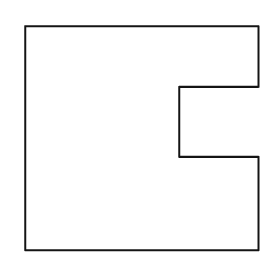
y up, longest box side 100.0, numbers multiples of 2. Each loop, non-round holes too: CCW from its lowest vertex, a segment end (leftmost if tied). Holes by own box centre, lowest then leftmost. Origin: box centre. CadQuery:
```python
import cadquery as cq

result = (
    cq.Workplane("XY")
    .moveTo(-50.0, -48.0)
    .lineTo(50.0, -48.0)
    .lineTo(50.0, -8.0)
    .lineTo(16.0, -8.0)
    .lineTo(16.0, 22.0)
    .lineTo(50.0, 22.0)
    .lineTo(50.0, 48.0)
    .lineTo(-50.0, 48.0)
    .close()
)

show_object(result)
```